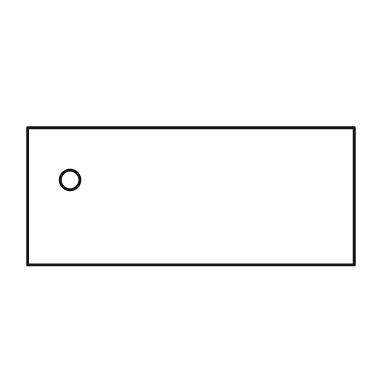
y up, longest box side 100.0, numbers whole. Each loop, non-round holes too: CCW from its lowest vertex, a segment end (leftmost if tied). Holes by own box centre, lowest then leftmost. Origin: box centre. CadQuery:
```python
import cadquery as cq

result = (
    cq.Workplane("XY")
    .moveTo(-50.0, -21.0)
    .lineTo(50.0, -21.0)
    .lineTo(50.0, 21.0)
    .lineTo(-50.0, 21.0)
    .close()
    .moveTo(-37.0, 5.0)
    .circle(3.0)
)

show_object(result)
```